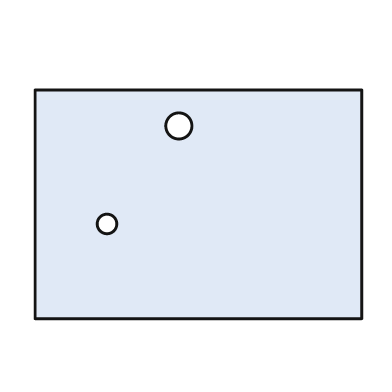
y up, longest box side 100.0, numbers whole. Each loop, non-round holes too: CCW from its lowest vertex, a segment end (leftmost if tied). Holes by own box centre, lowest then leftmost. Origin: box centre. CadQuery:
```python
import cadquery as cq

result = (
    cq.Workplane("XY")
    .moveTo(-50.0, -35.0)
    .lineTo(50.0, -35.0)
    .lineTo(50.0, 35.0)
    .lineTo(-50.0, 35.0)
    .close()
    .moveTo(-28.0, -6.0)
    .circle(3.0)
    .moveTo(-6.0, 24.0)
    .circle(4.0)
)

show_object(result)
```